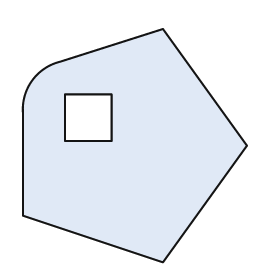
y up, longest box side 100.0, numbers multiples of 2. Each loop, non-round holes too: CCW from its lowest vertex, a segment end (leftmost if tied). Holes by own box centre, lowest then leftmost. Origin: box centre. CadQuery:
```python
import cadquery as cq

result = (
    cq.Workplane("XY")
    .moveTo(12.0, -50.0)
    .lineTo(48.0, 0.0)
    .lineTo(12.0, 50.0)
    .lineTo(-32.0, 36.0)
    .threePointArc((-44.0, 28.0), (-48.0, 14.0))
    .lineTo(-48.0, -30.0)
    .close()
    .moveTo(-30.0, 2.0)
    .lineTo(-10.0, 2.0)
    .lineTo(-10.0, 22.0)
    .lineTo(-30.0, 22.0)
    .close()
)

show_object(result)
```